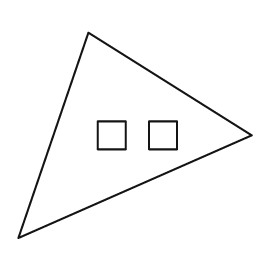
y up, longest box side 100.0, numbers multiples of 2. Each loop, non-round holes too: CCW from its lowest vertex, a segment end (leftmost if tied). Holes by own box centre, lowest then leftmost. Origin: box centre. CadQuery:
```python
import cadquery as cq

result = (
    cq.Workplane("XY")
    .moveTo(-50.0, -44.0)
    .lineTo(50.0, 0.0)
    .lineTo(-20.0, 44.0)
    .close()
    .moveTo(-16.0, -6.0)
    .lineTo(-4.0, -6.0)
    .lineTo(-4.0, 6.0)
    .lineTo(-16.0, 6.0)
    .close()
    .moveTo(6.0, -6.0)
    .lineTo(18.0, -6.0)
    .lineTo(18.0, 6.0)
    .lineTo(6.0, 6.0)
    .close()
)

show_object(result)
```